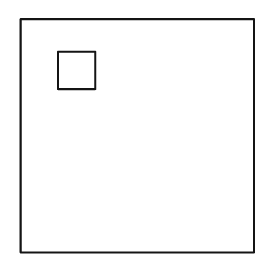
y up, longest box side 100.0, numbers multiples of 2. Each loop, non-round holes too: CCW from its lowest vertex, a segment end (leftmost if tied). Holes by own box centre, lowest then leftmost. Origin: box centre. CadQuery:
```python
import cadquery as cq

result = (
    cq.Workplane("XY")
    .moveTo(-50.0, -50.0)
    .lineTo(50.0, -50.0)
    .lineTo(50.0, 50.0)
    .lineTo(-50.0, 50.0)
    .close()
    .moveTo(-34.0, 20.0)
    .lineTo(-18.0, 20.0)
    .lineTo(-18.0, 36.0)
    .lineTo(-34.0, 36.0)
    .close()
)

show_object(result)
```